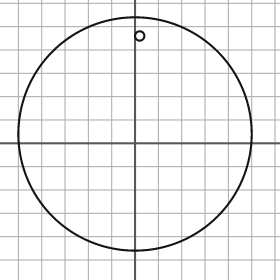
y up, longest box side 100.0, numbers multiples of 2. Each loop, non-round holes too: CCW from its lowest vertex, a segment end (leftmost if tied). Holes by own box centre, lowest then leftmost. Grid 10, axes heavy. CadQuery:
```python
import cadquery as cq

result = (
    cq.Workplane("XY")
    .moveTo(0.0, 4.0)
    .circle(50.0)
    .moveTo(2.0, 46.0)
    .circle(2.0)
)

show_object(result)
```